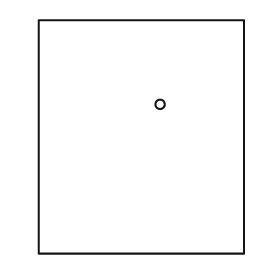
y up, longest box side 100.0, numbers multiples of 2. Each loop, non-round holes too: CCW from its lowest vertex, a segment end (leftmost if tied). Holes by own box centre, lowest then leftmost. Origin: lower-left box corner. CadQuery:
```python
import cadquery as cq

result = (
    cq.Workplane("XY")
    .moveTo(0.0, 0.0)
    .lineTo(88.0, 0.0)
    .lineTo(88.0, 100.0)
    .lineTo(0.0, 100.0)
    .close()
    .moveTo(52.0, 64.0)
    .circle(2.0)
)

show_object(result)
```